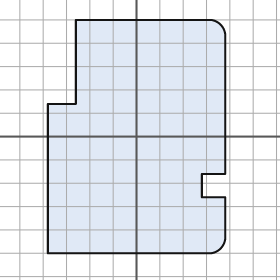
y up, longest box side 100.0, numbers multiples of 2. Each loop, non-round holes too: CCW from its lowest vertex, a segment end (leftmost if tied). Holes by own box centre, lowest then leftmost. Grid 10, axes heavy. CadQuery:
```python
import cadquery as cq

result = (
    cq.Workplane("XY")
    .moveTo(-38.0, -50.0)
    .lineTo(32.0, -50.0)
    .threePointArc((36.0, -48.0), (38.0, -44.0))
    .lineTo(38.0, -26.0)
    .lineTo(28.0, -26.0)
    .lineTo(28.0, -16.0)
    .lineTo(38.0, -16.0)
    .lineTo(38.0, 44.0)
    .threePointArc((36.0, 48.0), (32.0, 50.0))
    .lineTo(-26.0, 50.0)
    .lineTo(-26.0, 14.0)
    .lineTo(-38.0, 14.0)
    .close()
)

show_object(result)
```